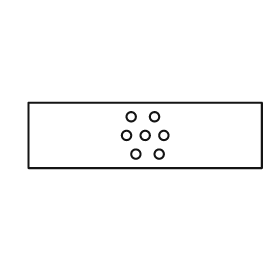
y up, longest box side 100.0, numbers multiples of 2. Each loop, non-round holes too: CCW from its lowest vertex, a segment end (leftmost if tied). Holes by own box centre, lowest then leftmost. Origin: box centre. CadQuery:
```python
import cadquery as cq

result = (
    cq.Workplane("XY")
    .moveTo(-50.0, -14.0)
    .lineTo(50.0, -14.0)
    .lineTo(50.0, 14.0)
    .lineTo(-50.0, 14.0)
    .close()
    .moveTo(-4.0, -8.0)
    .circle(2.0)
    .moveTo(6.0, -8.0)
    .circle(2.0)
    .moveTo(-8.0, 0.0)
    .circle(2.0)
    .moveTo(0.0, 0.0)
    .circle(2.0)
    .moveTo(8.0, 0.0)
    .circle(2.0)
    .moveTo(-6.0, 8.0)
    .circle(2.0)
    .moveTo(4.0, 8.0)
    .circle(2.0)
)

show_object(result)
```